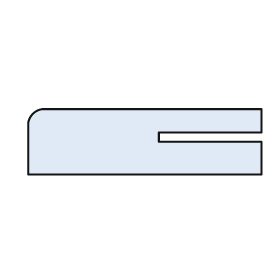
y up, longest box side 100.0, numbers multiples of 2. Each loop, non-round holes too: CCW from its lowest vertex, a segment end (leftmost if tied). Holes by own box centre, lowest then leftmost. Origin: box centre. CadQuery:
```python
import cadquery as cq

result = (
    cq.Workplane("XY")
    .moveTo(-50.0, -14.0)
    .lineTo(50.0, -14.0)
    .lineTo(50.0, 0.0)
    .lineTo(6.0, 0.0)
    .lineTo(6.0, 4.0)
    .lineTo(50.0, 4.0)
    .lineTo(50.0, 14.0)
    .lineTo(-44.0, 14.0)
    .threePointArc((-48.0, 12.0), (-50.0, 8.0))
    .close()
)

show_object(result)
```